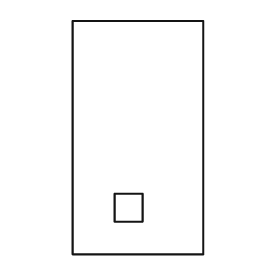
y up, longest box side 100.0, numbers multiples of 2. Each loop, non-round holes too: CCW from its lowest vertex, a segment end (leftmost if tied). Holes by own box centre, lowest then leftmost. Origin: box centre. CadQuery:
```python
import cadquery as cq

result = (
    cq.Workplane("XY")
    .moveTo(-28.0, -50.0)
    .lineTo(28.0, -50.0)
    .lineTo(28.0, 50.0)
    .lineTo(-28.0, 50.0)
    .close()
    .moveTo(-10.0, -36.0)
    .lineTo(2.0, -36.0)
    .lineTo(2.0, -24.0)
    .lineTo(-10.0, -24.0)
    .close()
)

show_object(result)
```